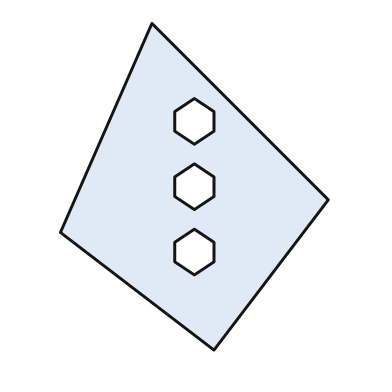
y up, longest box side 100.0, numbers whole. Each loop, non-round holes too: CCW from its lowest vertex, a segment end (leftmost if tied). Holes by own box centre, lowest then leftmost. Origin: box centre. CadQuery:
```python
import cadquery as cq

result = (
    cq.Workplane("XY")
    .moveTo(6.0, -50.0)
    .lineTo(41.0, -4.0)
    .lineTo(-13.0, 50.0)
    .lineTo(-41.0, -14.0)
    .close()
    .moveTo(0.0, -27.0)
    .lineTo(6.0, -23.0)
    .lineTo(6.0, -17.0)
    .lineTo(0.0, -13.0)
    .lineTo(-6.0, -17.0)
    .lineTo(-6.0, -23.0)
    .close()
    .moveTo(0.0, -7.0)
    .lineTo(6.0, -3.0)
    .lineTo(6.0, 3.0)
    .lineTo(0.0, 7.0)
    .lineTo(-6.0, 3.0)
    .lineTo(-6.0, -3.0)
    .close()
    .moveTo(0.0, 13.0)
    .lineTo(6.0, 17.0)
    .lineTo(6.0, 23.0)
    .lineTo(0.0, 27.0)
    .lineTo(-6.0, 23.0)
    .lineTo(-6.0, 17.0)
    .close()
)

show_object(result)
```